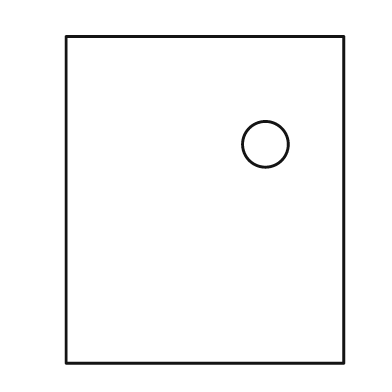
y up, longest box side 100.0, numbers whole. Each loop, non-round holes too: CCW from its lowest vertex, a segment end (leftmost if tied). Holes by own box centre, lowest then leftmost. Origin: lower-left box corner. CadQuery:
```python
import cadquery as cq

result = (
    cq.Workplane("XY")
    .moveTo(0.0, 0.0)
    .lineTo(85.0, 0.0)
    .lineTo(85.0, 100.0)
    .lineTo(0.0, 100.0)
    .close()
    .moveTo(61.0, 67.0)
    .circle(7.0)
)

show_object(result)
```